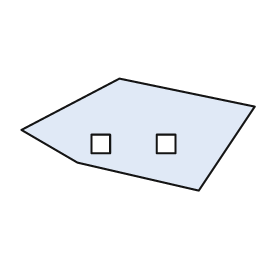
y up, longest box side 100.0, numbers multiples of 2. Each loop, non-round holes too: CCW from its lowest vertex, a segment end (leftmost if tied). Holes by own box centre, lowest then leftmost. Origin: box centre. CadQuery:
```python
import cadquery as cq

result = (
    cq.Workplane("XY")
    .moveTo(26.0, -24.0)
    .lineTo(50.0, 12.0)
    .lineTo(-8.0, 24.0)
    .lineTo(-50.0, 2.0)
    .lineTo(-26.0, -12.0)
    .close()
    .moveTo(-20.0, -8.0)
    .lineTo(-12.0, -8.0)
    .lineTo(-12.0, 0.0)
    .lineTo(-20.0, 0.0)
    .close()
    .moveTo(8.0, -8.0)
    .lineTo(16.0, -8.0)
    .lineTo(16.0, 0.0)
    .lineTo(8.0, 0.0)
    .close()
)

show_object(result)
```